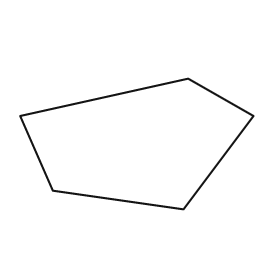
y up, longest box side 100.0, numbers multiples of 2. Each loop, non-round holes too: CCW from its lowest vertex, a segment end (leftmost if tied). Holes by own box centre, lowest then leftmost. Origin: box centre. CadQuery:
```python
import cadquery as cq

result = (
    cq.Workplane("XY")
    .moveTo(20.0, -28.0)
    .lineTo(50.0, 12.0)
    .lineTo(22.0, 28.0)
    .lineTo(-50.0, 12.0)
    .lineTo(-36.0, -20.0)
    .close()
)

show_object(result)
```